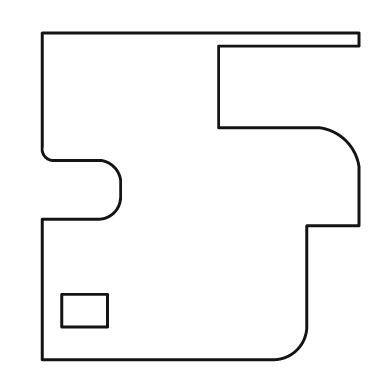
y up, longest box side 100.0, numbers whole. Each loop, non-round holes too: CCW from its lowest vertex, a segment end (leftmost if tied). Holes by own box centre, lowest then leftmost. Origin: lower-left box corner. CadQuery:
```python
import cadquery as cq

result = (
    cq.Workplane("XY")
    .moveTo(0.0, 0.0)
    .lineTo(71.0, 0.0)
    .threePointArc((78.0, 3.0), (81.0, 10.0))
    .lineTo(81.0, 41.0)
    .lineTo(97.0, 41.0)
    .lineTo(97.0, 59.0)
    .threePointArc((93.0, 67.0), (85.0, 71.0))
    .lineTo(54.0, 71.0)
    .lineTo(54.0, 96.0)
    .lineTo(97.0, 96.0)
    .lineTo(97.0, 100.0)
    .lineTo(0.0, 100.0)
    .lineTo(0.0, 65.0)
    .threePointArc((1.0, 62.0), (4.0, 61.0))
    .lineTo(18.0, 61.0)
    .threePointArc((22.0, 59.0), (24.0, 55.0))
    .lineTo(24.0, 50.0)
    .threePointArc((22.0, 45.0), (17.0, 43.0))
    .lineTo(0.0, 43.0)
    .close()
    .moveTo(6.0, 10.0)
    .lineTo(20.0, 10.0)
    .lineTo(20.0, 20.0)
    .lineTo(6.0, 20.0)
    .close()
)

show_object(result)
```